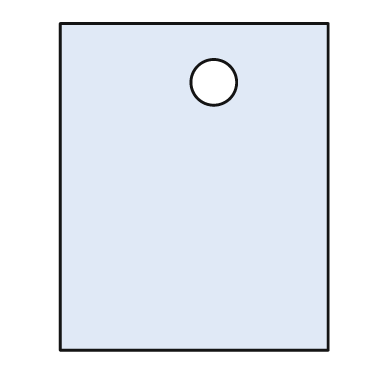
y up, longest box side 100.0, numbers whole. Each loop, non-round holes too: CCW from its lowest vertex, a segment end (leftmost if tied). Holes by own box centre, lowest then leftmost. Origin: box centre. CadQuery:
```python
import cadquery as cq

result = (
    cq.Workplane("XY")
    .moveTo(-41.0, -50.0)
    .lineTo(41.0, -50.0)
    .lineTo(41.0, 50.0)
    .lineTo(-41.0, 50.0)
    .close()
    .moveTo(6.0, 32.0)
    .circle(7.0)
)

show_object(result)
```